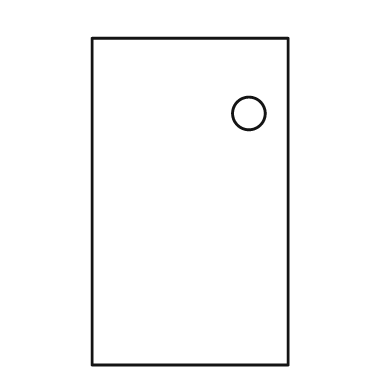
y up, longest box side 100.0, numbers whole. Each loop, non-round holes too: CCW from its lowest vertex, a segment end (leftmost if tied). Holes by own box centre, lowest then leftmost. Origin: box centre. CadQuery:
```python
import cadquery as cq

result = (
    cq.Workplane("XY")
    .moveTo(-30.0, -50.0)
    .lineTo(30.0, -50.0)
    .lineTo(30.0, 50.0)
    .lineTo(-30.0, 50.0)
    .close()
    .moveTo(18.0, 27.0)
    .circle(5.0)
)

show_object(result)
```